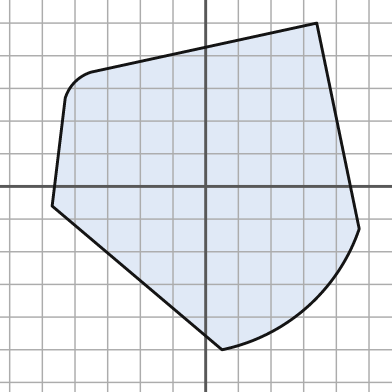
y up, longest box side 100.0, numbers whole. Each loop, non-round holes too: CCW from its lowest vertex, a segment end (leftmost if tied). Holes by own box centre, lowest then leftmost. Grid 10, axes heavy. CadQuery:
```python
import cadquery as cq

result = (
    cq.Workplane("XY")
    .moveTo(5.0, -50.0)
    .threePointArc((31.0, -37.0), (47.0, -13.0))
    .lineTo(34.0, 50.0)
    .lineTo(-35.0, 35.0)
    .threePointArc((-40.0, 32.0), (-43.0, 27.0))
    .lineTo(-47.0, -6.0)
    .close()
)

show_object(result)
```